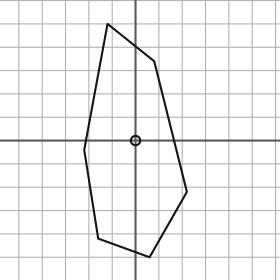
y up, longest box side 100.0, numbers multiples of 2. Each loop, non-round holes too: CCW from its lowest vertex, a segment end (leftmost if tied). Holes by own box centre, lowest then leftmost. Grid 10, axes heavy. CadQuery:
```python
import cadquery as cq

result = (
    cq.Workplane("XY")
    .moveTo(6.0, -50.0)
    .lineTo(22.0, -22.0)
    .lineTo(8.0, 34.0)
    .lineTo(-12.0, 50.0)
    .lineTo(-22.0, -4.0)
    .lineTo(-16.0, -42.0)
    .close()
    .moveTo(0.0, 0.0)
    .circle(2.0)
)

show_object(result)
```